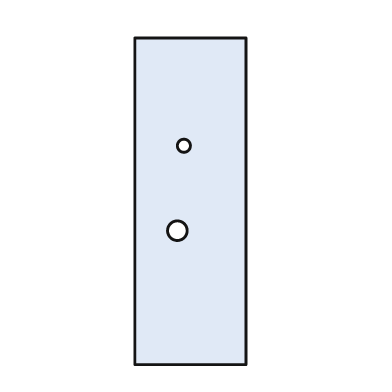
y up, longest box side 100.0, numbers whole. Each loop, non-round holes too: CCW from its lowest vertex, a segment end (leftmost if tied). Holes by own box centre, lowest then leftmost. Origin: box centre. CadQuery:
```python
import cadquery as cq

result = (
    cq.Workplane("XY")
    .moveTo(-17.0, -50.0)
    .lineTo(17.0, -50.0)
    .lineTo(17.0, 50.0)
    .lineTo(-17.0, 50.0)
    .close()
    .moveTo(-4.0, -9.0)
    .circle(3.0)
    .moveTo(-2.0, 17.0)
    .circle(2.0)
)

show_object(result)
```